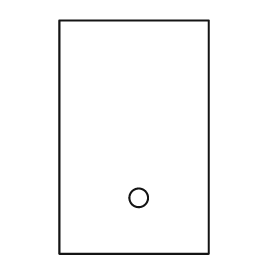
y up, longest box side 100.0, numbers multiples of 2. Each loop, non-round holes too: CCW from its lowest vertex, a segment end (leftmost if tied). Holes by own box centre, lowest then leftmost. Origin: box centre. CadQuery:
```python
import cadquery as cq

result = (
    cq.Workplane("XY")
    .moveTo(-32.0, -50.0)
    .lineTo(32.0, -50.0)
    .lineTo(32.0, 50.0)
    .lineTo(-32.0, 50.0)
    .close()
    .moveTo(2.0, -26.0)
    .circle(4.0)
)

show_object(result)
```